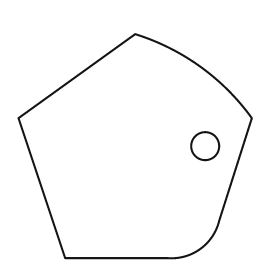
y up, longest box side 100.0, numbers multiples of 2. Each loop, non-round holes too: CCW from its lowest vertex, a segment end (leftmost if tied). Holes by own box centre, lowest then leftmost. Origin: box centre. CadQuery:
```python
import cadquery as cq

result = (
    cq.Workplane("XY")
    .moveTo(-30.0, -48.0)
    .lineTo(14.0, -48.0)
    .threePointArc((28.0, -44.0), (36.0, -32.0))
    .lineTo(50.0, 12.0)
    .threePointArc((28.0, 34.0), (0.0, 48.0))
    .lineTo(-50.0, 12.0)
    .close()
    .moveTo(30.0, 0.0)
    .circle(6.0)
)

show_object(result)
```